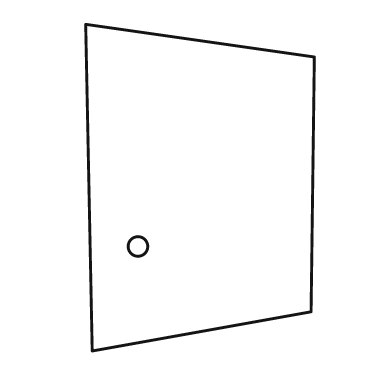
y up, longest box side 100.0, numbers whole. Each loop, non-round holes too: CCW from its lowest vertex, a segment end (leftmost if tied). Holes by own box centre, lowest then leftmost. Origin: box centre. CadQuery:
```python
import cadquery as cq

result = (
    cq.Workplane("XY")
    .moveTo(-33.0, -50.0)
    .lineTo(34.0, -38.0)
    .lineTo(35.0, 40.0)
    .lineTo(-35.0, 50.0)
    .close()
    .moveTo(-19.0, -18.0)
    .circle(3.0)
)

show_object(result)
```